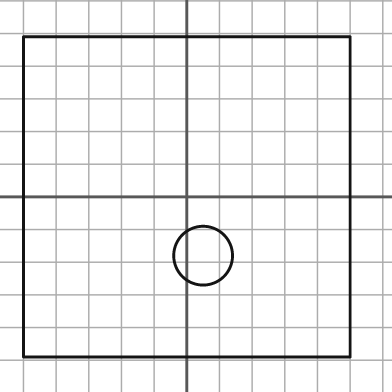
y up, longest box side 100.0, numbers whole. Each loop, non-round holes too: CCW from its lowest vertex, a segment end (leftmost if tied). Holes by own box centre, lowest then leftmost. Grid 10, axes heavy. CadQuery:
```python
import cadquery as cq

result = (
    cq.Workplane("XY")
    .moveTo(-50.0, -49.0)
    .lineTo(50.0, -49.0)
    .lineTo(50.0, 49.0)
    .lineTo(-50.0, 49.0)
    .close()
    .moveTo(5.0, -18.0)
    .circle(9.0)
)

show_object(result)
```